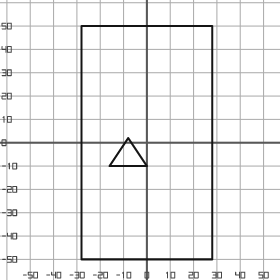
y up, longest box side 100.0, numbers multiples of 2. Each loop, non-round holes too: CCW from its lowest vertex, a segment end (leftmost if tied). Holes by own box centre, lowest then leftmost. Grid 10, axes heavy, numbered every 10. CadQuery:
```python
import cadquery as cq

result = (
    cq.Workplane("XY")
    .moveTo(-28.0, -50.0)
    .lineTo(28.0, -50.0)
    .lineTo(28.0, 50.0)
    .lineTo(-28.0, 50.0)
    .close()
    .moveTo(-16.0, -10.0)
    .lineTo(0.0, -10.0)
    .lineTo(-8.0, 2.0)
    .close()
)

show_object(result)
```